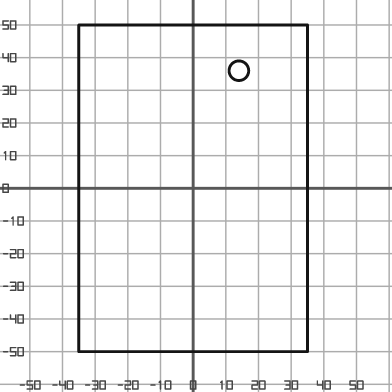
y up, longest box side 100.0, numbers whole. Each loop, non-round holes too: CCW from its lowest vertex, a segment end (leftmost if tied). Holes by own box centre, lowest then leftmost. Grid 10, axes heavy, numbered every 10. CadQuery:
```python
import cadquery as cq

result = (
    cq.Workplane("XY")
    .moveTo(-35.0, -50.0)
    .lineTo(35.0, -50.0)
    .lineTo(35.0, 50.0)
    .lineTo(-35.0, 50.0)
    .close()
    .moveTo(14.0, 36.0)
    .circle(3.0)
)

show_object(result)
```